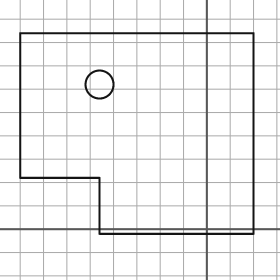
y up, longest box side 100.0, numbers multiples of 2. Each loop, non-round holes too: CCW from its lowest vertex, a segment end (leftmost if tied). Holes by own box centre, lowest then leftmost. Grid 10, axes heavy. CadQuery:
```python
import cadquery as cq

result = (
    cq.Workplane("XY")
    .moveTo(-46.0, -2.0)
    .lineTo(20.0, -2.0)
    .lineTo(20.0, 84.0)
    .lineTo(-80.0, 84.0)
    .lineTo(-80.0, 22.0)
    .lineTo(-46.0, 22.0)
    .close()
    .moveTo(-46.0, 62.0)
    .circle(6.0)
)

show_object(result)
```